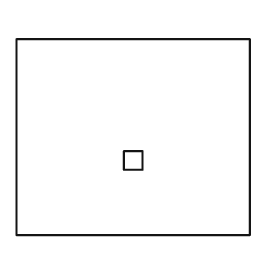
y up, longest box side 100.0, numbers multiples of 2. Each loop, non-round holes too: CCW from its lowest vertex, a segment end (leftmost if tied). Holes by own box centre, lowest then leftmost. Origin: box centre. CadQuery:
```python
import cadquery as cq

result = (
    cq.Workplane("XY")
    .moveTo(-50.0, -42.0)
    .lineTo(50.0, -42.0)
    .lineTo(50.0, 42.0)
    .lineTo(-50.0, 42.0)
    .close()
    .moveTo(-4.0, -14.0)
    .lineTo(4.0, -14.0)
    .lineTo(4.0, -6.0)
    .lineTo(-4.0, -6.0)
    .close()
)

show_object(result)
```